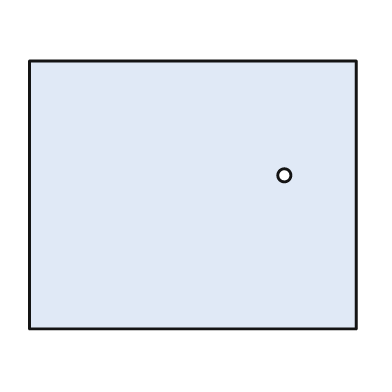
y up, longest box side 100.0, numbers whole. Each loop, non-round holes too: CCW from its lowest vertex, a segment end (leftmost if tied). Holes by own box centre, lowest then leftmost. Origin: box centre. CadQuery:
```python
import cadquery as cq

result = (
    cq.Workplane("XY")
    .moveTo(-50.0, -41.0)
    .lineTo(50.0, -41.0)
    .lineTo(50.0, 41.0)
    .lineTo(-50.0, 41.0)
    .close()
    .moveTo(28.0, 6.0)
    .circle(2.0)
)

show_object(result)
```